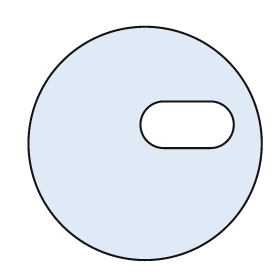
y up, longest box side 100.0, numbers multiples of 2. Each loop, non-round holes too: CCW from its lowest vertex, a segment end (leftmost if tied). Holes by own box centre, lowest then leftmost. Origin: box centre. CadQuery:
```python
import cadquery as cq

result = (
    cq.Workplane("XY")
    .moveTo(0.0, 0.0)
    .circle(50.0)
    .moveTo(8.0, -2.0)
    .lineTo(28.0, -2.0)
    .threePointArc((38.0, 8.0), (28.0, 18.0))
    .lineTo(8.0, 18.0)
    .threePointArc((-2.0, 8.0), (8.0, -2.0))
    .close()
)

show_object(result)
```